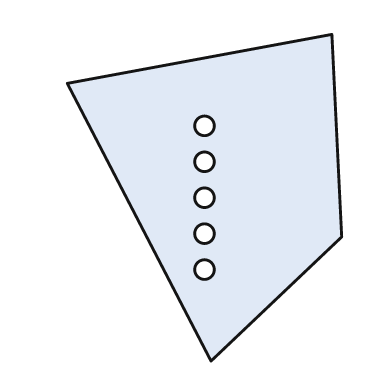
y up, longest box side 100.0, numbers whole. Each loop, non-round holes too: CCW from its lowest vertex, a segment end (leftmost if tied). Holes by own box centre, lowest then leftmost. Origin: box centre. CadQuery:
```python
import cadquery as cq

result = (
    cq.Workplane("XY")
    .moveTo(2.0, -50.0)
    .lineTo(42.0, -12.0)
    .lineTo(39.0, 50.0)
    .lineTo(-42.0, 35.0)
    .close()
    .moveTo(0.0, -22.0)
    .circle(3.0)
    .moveTo(0.0, -11.0)
    .circle(3.0)
    .moveTo(0.0, 0.0)
    .circle(3.0)
    .moveTo(0.0, 11.0)
    .circle(3.0)
    .moveTo(0.0, 22.0)
    .circle(3.0)
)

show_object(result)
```